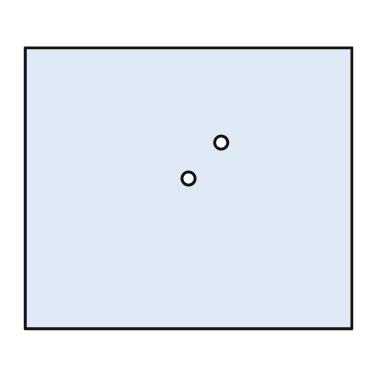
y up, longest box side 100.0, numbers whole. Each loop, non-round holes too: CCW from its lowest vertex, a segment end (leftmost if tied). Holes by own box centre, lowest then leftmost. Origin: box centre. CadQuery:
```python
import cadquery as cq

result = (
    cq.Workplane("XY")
    .moveTo(-50.0, -43.0)
    .lineTo(50.0, -43.0)
    .lineTo(50.0, 43.0)
    .lineTo(-50.0, 43.0)
    .close()
    .moveTo(0.0, 3.0)
    .circle(2.0)
    .moveTo(10.0, 14.0)
    .circle(2.0)
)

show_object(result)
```